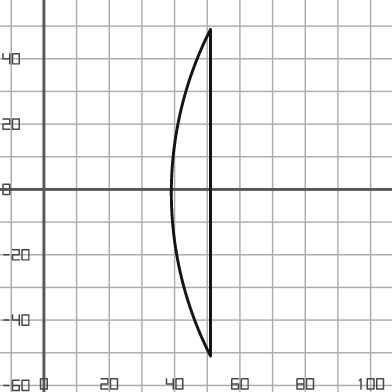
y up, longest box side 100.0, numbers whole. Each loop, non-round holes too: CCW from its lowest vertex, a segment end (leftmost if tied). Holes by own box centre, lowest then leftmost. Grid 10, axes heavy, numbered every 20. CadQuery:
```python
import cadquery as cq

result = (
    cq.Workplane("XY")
    .moveTo(51.0, -51.0)
    .lineTo(51.0, 49.0)
    .threePointArc((39.0, -1.0), (51.0, -51.0))
    .close()
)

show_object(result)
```